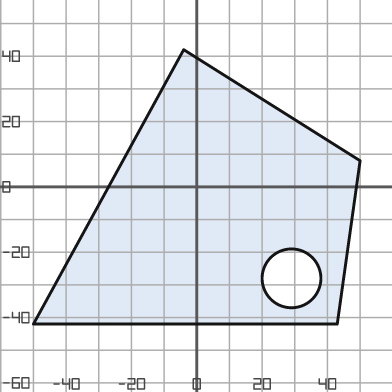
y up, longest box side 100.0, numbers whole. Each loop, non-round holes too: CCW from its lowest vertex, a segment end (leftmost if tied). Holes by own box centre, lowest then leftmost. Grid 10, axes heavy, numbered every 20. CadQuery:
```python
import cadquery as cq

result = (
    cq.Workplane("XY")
    .moveTo(-50.0, -42.0)
    .lineTo(43.0, -42.0)
    .lineTo(50.0, 8.0)
    .lineTo(-4.0, 42.0)
    .close()
    .moveTo(29.0, -28.0)
    .circle(9.0)
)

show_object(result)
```